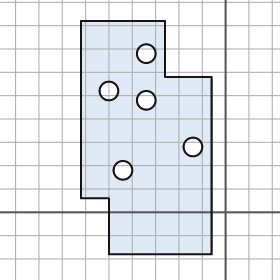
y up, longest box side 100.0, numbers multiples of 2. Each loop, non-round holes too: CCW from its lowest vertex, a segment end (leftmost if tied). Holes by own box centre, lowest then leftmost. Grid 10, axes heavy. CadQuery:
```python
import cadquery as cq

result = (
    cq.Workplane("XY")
    .moveTo(-50.0, -18.0)
    .lineTo(-6.0, -18.0)
    .lineTo(-6.0, 58.0)
    .lineTo(-26.0, 58.0)
    .lineTo(-26.0, 82.0)
    .lineTo(-62.0, 82.0)
    .lineTo(-62.0, 6.0)
    .lineTo(-50.0, 6.0)
    .close()
    .moveTo(-44.0, 18.0)
    .circle(4.0)
    .moveTo(-14.0, 28.0)
    .circle(4.0)
    .moveTo(-34.0, 48.0)
    .circle(4.0)
    .moveTo(-50.0, 52.0)
    .circle(4.0)
    .moveTo(-34.0, 68.0)
    .circle(4.0)
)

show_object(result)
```